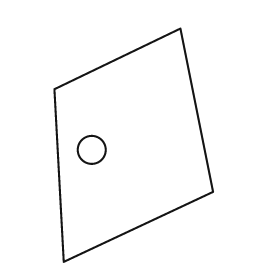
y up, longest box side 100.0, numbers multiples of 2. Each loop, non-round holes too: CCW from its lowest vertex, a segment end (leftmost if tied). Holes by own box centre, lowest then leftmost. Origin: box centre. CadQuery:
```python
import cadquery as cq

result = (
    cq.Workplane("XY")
    .moveTo(-30.0, -50.0)
    .lineTo(34.0, -20.0)
    .lineTo(20.0, 50.0)
    .lineTo(-34.0, 24.0)
    .close()
    .moveTo(-18.0, -2.0)
    .circle(6.0)
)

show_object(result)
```